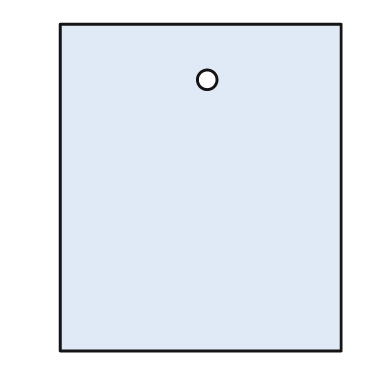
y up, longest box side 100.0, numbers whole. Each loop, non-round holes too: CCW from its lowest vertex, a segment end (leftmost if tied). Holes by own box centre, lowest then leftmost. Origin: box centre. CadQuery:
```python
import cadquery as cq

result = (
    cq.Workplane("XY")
    .moveTo(-43.0, -50.0)
    .lineTo(43.0, -50.0)
    .lineTo(43.0, 50.0)
    .lineTo(-43.0, 50.0)
    .close()
    .moveTo(2.0, 33.0)
    .circle(3.0)
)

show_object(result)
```